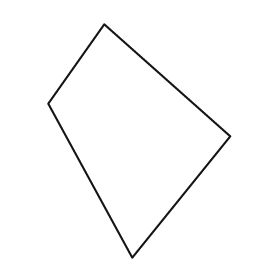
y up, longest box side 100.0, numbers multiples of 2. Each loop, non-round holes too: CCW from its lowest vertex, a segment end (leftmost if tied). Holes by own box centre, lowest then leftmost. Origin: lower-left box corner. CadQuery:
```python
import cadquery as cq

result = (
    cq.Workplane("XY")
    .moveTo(36.0, 0.0)
    .lineTo(78.0, 52.0)
    .lineTo(24.0, 100.0)
    .lineTo(0.0, 66.0)
    .close()
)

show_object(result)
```